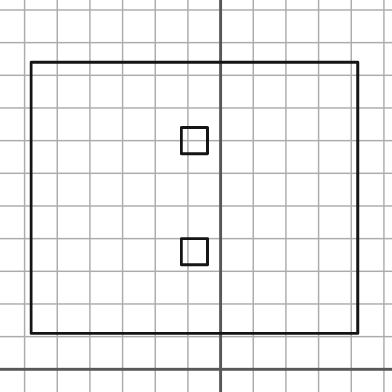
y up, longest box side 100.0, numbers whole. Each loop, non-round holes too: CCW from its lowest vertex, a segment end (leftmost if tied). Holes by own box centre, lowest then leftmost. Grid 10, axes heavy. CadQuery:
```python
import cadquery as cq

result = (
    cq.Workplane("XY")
    .moveTo(-58.0, 11.0)
    .lineTo(42.0, 11.0)
    .lineTo(42.0, 94.0)
    .lineTo(-58.0, 94.0)
    .close()
    .moveTo(-12.0, 32.0)
    .lineTo(-4.0, 32.0)
    .lineTo(-4.0, 40.0)
    .lineTo(-12.0, 40.0)
    .close()
    .moveTo(-12.0, 66.0)
    .lineTo(-4.0, 66.0)
    .lineTo(-4.0, 74.0)
    .lineTo(-12.0, 74.0)
    .close()
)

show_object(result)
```